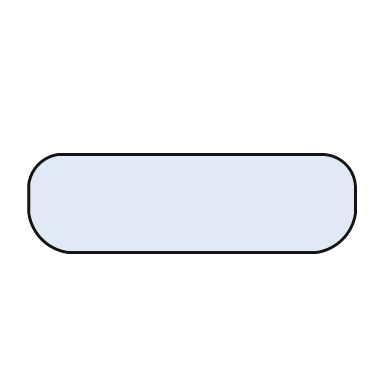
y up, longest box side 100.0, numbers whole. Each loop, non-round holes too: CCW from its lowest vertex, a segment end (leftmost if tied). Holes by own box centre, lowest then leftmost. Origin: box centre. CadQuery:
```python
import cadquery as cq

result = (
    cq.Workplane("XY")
    .moveTo(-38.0, -15.0)
    .lineTo(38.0, -15.0)
    .threePointArc((46.0, -11.0), (50.0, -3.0))
    .lineTo(50.0, 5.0)
    .threePointArc((47.0, 12.0), (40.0, 15.0))
    .lineTo(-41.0, 15.0)
    .threePointArc((-47.0, 12.0), (-50.0, 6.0))
    .lineTo(-50.0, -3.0)
    .threePointArc((-46.0, -11.0), (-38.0, -15.0))
    .close()
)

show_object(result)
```